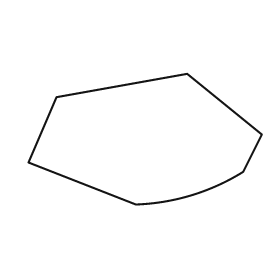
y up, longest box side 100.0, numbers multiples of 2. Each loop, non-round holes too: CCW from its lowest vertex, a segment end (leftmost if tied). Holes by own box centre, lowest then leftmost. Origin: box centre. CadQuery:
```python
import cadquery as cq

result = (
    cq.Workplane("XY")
    .moveTo(-4.0, -28.0)
    .threePointArc((20.0, -24.0), (42.0, -14.0))
    .lineTo(50.0, 2.0)
    .lineTo(18.0, 28.0)
    .lineTo(-38.0, 18.0)
    .lineTo(-50.0, -10.0)
    .close()
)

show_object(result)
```